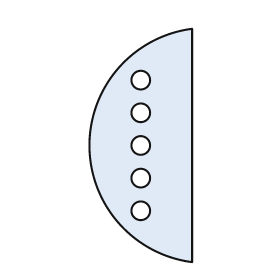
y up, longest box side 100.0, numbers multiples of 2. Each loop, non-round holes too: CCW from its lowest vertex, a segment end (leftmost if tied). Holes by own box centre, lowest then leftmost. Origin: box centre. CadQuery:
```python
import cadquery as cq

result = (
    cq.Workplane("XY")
    .moveTo(22.0, -50.0)
    .lineTo(22.0, 50.0)
    .threePointArc((-22.0, 0.0), (22.0, -50.0))
    .close()
    .moveTo(0.0, -28.0)
    .circle(4.0)
    .moveTo(0.0, -14.0)
    .circle(4.0)
    .moveTo(0.0, 0.0)
    .circle(4.0)
    .moveTo(0.0, 14.0)
    .circle(4.0)
    .moveTo(0.0, 28.0)
    .circle(4.0)
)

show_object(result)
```